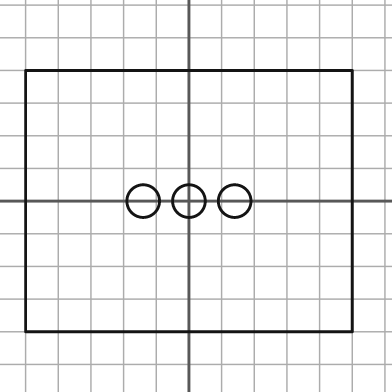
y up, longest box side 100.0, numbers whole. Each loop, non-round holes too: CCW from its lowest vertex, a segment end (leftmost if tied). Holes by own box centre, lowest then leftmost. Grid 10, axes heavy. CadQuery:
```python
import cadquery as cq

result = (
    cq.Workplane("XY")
    .moveTo(-50.0, -40.0)
    .lineTo(50.0, -40.0)
    .lineTo(50.0, 40.0)
    .lineTo(-50.0, 40.0)
    .close()
    .moveTo(-14.0, 0.0)
    .circle(5.0)
    .moveTo(0.0, 0.0)
    .circle(5.0)
    .moveTo(14.0, 0.0)
    .circle(5.0)
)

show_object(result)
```